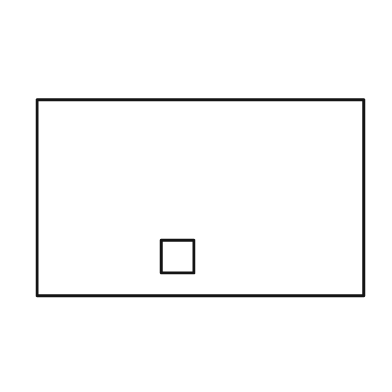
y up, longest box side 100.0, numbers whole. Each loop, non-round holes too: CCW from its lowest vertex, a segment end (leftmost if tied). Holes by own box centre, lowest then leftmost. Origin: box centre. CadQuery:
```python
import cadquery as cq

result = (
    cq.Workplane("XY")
    .moveTo(-50.0, -30.0)
    .lineTo(50.0, -30.0)
    .lineTo(50.0, 30.0)
    .lineTo(-50.0, 30.0)
    .close()
    .moveTo(-12.0, -23.0)
    .lineTo(-2.0, -23.0)
    .lineTo(-2.0, -13.0)
    .lineTo(-12.0, -13.0)
    .close()
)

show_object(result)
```